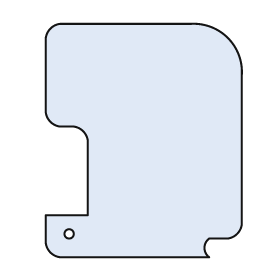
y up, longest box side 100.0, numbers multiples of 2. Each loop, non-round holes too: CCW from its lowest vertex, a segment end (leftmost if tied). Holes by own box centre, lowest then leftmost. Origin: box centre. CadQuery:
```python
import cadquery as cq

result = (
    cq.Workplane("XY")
    .moveTo(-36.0, -50.0)
    .lineTo(28.0, -50.0)
    .threePointArc((26.0, -46.0), (28.0, -42.0))
    .lineTo(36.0, -42.0)
    .threePointArc((40.0, -40.0), (42.0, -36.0))
    .lineTo(42.0, 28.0)
    .threePointArc((36.0, 44.0), (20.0, 50.0))
    .lineTo(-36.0, 50.0)
    .threePointArc((-40.0, 48.0), (-42.0, 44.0))
    .lineTo(-42.0, 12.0)
    .threePointArc((-40.0, 8.0), (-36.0, 6.0))
    .lineTo(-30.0, 6.0)
    .threePointArc((-26.0, 4.0), (-24.0, 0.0))
    .lineTo(-24.0, -32.0)
    .lineTo(-42.0, -32.0)
    .lineTo(-42.0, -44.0)
    .threePointArc((-40.0, -48.0), (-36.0, -50.0))
    .close()
    .moveTo(-32.0, -40.0)
    .circle(2.0)
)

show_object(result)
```